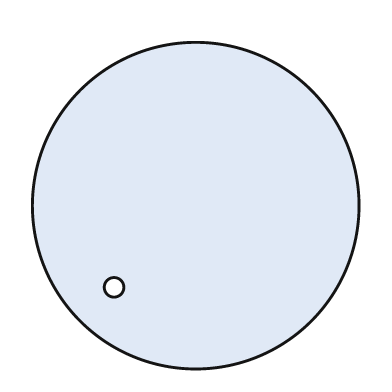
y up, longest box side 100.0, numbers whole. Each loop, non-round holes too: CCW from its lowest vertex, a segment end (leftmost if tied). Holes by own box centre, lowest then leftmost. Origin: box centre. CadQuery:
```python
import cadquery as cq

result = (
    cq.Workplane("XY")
    .moveTo(0.0, 0.0)
    .circle(50.0)
    .moveTo(-25.0, -25.0)
    .circle(3.0)
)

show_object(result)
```